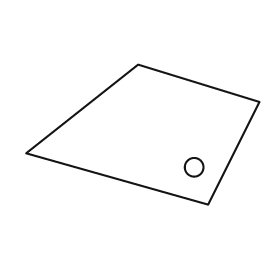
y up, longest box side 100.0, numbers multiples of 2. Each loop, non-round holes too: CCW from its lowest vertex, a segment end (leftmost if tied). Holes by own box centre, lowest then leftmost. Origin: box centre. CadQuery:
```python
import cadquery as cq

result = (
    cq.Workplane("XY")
    .moveTo(28.0, -30.0)
    .lineTo(50.0, 14.0)
    .lineTo(-2.0, 30.0)
    .lineTo(-50.0, -8.0)
    .close()
    .moveTo(22.0, -14.0)
    .circle(4.0)
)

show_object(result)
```